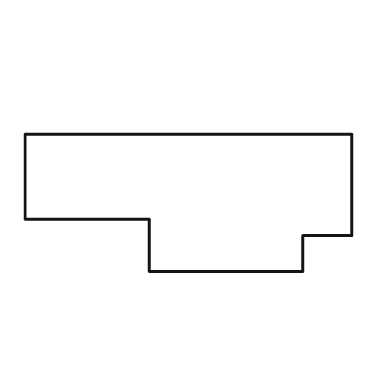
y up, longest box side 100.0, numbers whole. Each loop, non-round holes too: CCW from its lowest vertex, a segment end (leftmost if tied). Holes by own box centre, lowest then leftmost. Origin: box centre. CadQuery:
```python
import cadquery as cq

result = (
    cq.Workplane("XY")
    .moveTo(-12.0, -21.0)
    .lineTo(35.0, -21.0)
    .lineTo(35.0, -10.0)
    .lineTo(50.0, -10.0)
    .lineTo(50.0, 21.0)
    .lineTo(-50.0, 21.0)
    .lineTo(-50.0, -5.0)
    .lineTo(-12.0, -5.0)
    .close()
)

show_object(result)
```